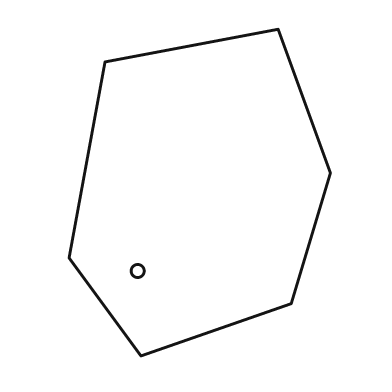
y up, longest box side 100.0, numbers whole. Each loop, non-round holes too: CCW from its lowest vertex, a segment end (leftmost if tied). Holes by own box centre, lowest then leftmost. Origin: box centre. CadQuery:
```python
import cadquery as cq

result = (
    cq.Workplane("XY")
    .moveTo(-18.0, -50.0)
    .lineTo(28.0, -34.0)
    .lineTo(40.0, 6.0)
    .lineTo(24.0, 50.0)
    .lineTo(-29.0, 40.0)
    .lineTo(-40.0, -20.0)
    .close()
    .moveTo(-19.0, -24.0)
    .circle(2.0)
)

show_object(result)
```